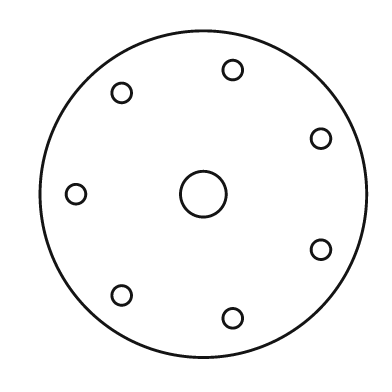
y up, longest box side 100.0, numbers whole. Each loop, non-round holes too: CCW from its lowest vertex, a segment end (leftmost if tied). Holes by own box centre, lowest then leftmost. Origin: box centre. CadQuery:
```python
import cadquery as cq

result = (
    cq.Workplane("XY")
    .moveTo(0.0, 0.0)
    .circle(50.0)
    .moveTo(9.0, -38.0)
    .circle(3.0)
    .moveTo(-25.0, -31.0)
    .circle(3.0)
    .moveTo(36.0, -17.0)
    .circle(3.0)
    .moveTo(-39.0, 0.0)
    .circle(3.0)
    .moveTo(0.0, 0.0)
    .circle(7.0)
    .moveTo(36.0, 17.0)
    .circle(3.0)
    .moveTo(-25.0, 31.0)
    .circle(3.0)
    .moveTo(9.0, 38.0)
    .circle(3.0)
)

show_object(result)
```